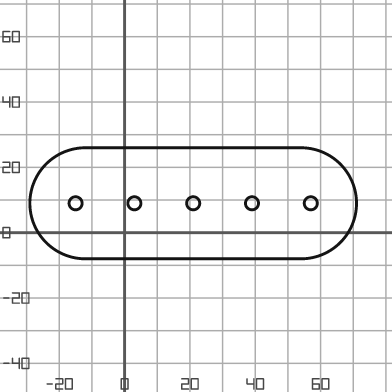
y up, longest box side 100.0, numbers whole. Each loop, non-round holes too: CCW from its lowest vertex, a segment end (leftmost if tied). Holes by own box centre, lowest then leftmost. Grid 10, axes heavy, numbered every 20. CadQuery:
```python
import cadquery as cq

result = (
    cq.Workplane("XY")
    .moveTo(-12.0, -8.0)
    .lineTo(54.0, -8.0)
    .threePointArc((71.0, 9.0), (54.0, 26.0))
    .lineTo(-12.0, 26.0)
    .threePointArc((-29.0, 9.0), (-12.0, -8.0))
    .close()
    .moveTo(-15.0, 9.0)
    .circle(2.0)
    .moveTo(3.0, 9.0)
    .circle(2.0)
    .moveTo(21.0, 9.0)
    .circle(2.0)
    .moveTo(39.0, 9.0)
    .circle(2.0)
    .moveTo(57.0, 9.0)
    .circle(2.0)
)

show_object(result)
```